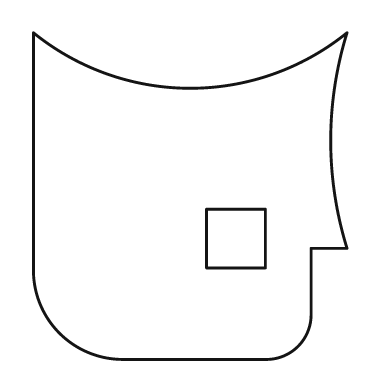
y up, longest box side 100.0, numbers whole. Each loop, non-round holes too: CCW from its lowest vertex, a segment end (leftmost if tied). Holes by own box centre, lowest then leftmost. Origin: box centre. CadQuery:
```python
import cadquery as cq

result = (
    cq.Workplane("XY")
    .moveTo(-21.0, -50.0)
    .lineTo(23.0, -50.0)
    .threePointArc((33.0, -46.0), (37.0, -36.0))
    .lineTo(37.0, -16.0)
    .lineTo(48.0, -16.0)
    .threePointArc((43.0, 17.0), (48.0, 50.0))
    .threePointArc((0.0, 33.0), (-48.0, 50.0))
    .lineTo(-48.0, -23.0)
    .threePointArc((-40.0, -42.0), (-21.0, -50.0))
    .close()
    .moveTo(5.0, -22.0)
    .lineTo(23.0, -22.0)
    .lineTo(23.0, -4.0)
    .lineTo(5.0, -4.0)
    .close()
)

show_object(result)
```